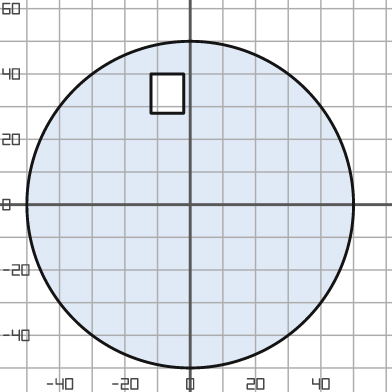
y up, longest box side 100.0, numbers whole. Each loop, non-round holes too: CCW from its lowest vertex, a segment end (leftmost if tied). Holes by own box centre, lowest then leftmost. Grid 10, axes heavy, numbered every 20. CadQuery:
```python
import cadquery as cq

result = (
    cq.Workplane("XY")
    .moveTo(0.0, 0.0)
    .circle(50.0)
    .moveTo(-12.0, 28.0)
    .lineTo(-2.0, 28.0)
    .lineTo(-2.0, 40.0)
    .lineTo(-12.0, 40.0)
    .close()
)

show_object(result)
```